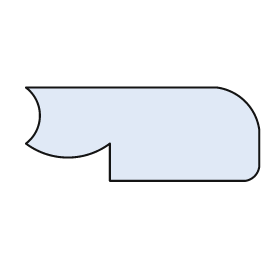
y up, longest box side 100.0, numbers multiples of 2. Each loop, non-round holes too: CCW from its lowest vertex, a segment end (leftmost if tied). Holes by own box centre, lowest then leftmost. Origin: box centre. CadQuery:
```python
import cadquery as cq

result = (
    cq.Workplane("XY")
    .moveTo(-14.0, -20.0)
    .lineTo(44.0, -20.0)
    .threePointArc((48.0, -18.0), (50.0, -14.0))
    .lineTo(50.0, 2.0)
    .threePointArc((44.0, 14.0), (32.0, 20.0))
    .lineTo(-50.0, 20.0)
    .threePointArc((-44.0, 8.0), (-50.0, -4.0))
    .threePointArc((-32.0, -10.0), (-14.0, -4.0))
    .close()
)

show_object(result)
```